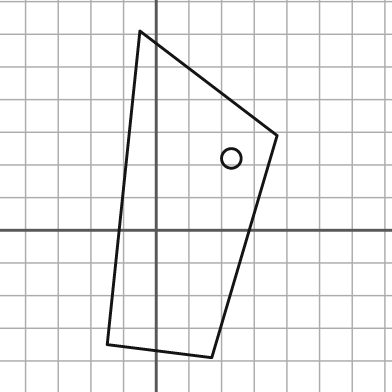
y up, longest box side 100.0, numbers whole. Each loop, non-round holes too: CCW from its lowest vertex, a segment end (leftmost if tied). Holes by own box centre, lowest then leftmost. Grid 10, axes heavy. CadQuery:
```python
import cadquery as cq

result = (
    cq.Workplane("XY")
    .moveTo(17.0, -39.0)
    .lineTo(37.0, 29.0)
    .lineTo(-5.0, 61.0)
    .lineTo(-15.0, -35.0)
    .close()
    .moveTo(23.0, 22.0)
    .circle(3.0)
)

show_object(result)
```